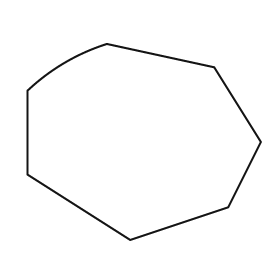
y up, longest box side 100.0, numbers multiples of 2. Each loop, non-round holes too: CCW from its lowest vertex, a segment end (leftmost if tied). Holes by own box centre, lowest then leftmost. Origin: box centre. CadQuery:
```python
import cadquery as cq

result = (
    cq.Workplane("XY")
    .moveTo(-6.0, -42.0)
    .lineTo(36.0, -28.0)
    .lineTo(50.0, 0.0)
    .lineTo(30.0, 32.0)
    .lineTo(-16.0, 42.0)
    .threePointArc((-34.0, 34.0), (-50.0, 22.0))
    .lineTo(-50.0, -14.0)
    .close()
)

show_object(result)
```